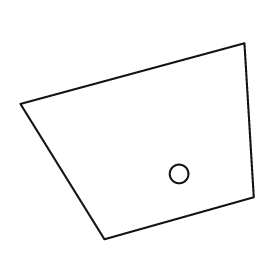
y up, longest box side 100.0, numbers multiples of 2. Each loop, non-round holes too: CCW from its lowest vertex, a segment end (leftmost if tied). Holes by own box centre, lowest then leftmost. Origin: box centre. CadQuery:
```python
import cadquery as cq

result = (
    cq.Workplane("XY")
    .moveTo(-14.0, -42.0)
    .lineTo(50.0, -24.0)
    .lineTo(46.0, 42.0)
    .lineTo(-50.0, 16.0)
    .close()
    .moveTo(18.0, -14.0)
    .circle(4.0)
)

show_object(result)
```